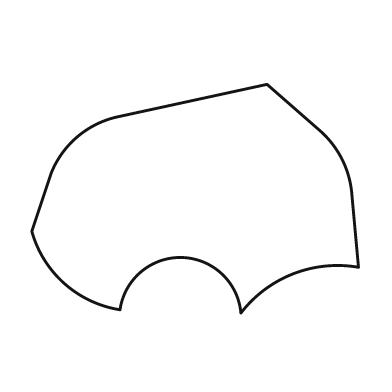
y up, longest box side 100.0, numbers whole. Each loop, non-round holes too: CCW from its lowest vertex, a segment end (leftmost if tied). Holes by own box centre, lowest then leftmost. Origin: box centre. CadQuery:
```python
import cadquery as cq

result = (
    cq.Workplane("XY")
    .moveTo(14.0, -35.0)
    .threePointArc((30.0, -23.0), (50.0, -21.0))
    .lineTo(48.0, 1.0)
    .threePointArc((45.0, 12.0), (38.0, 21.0))
    .lineTo(22.0, 35.0)
    .lineTo(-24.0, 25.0)
    .threePointArc((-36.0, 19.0), (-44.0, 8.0))
    .lineTo(-50.0, -10.0)
    .threePointArc((-40.0, -26.0), (-23.0, -34.0))
    .threePointArc((-4.0, -18.0), (14.0, -35.0))
    .close()
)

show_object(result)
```